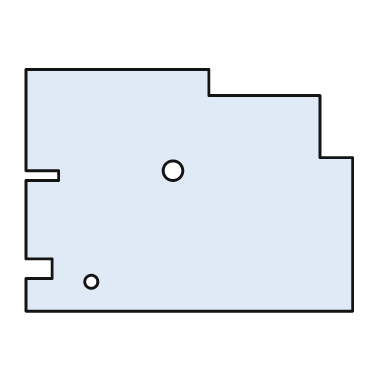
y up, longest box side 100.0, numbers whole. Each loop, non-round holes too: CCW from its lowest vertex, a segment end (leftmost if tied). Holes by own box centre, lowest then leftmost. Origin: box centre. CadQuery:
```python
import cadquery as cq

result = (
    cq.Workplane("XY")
    .moveTo(-50.0, -37.0)
    .lineTo(50.0, -37.0)
    .lineTo(50.0, 10.0)
    .lineTo(40.0, 10.0)
    .lineTo(40.0, 29.0)
    .lineTo(6.0, 29.0)
    .lineTo(6.0, 37.0)
    .lineTo(-50.0, 37.0)
    .lineTo(-50.0, 6.0)
    .lineTo(-40.0, 6.0)
    .lineTo(-40.0, 3.0)
    .lineTo(-50.0, 3.0)
    .lineTo(-50.0, -21.0)
    .lineTo(-42.0, -21.0)
    .lineTo(-42.0, -27.0)
    .lineTo(-50.0, -27.0)
    .close()
    .moveTo(-30.0, -28.0)
    .circle(2.0)
    .moveTo(-5.0, 6.0)
    .circle(3.0)
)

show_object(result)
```